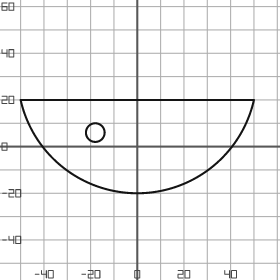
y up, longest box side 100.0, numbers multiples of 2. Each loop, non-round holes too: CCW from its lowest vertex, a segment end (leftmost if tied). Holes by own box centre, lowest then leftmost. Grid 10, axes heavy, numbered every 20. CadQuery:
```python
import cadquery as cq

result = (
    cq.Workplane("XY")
    .moveTo(-50.0, 20.0)
    .threePointArc((0.0, -20.0), (50.0, 20.0))
    .close()
    .moveTo(-18.0, 6.0)
    .circle(4.0)
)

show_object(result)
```